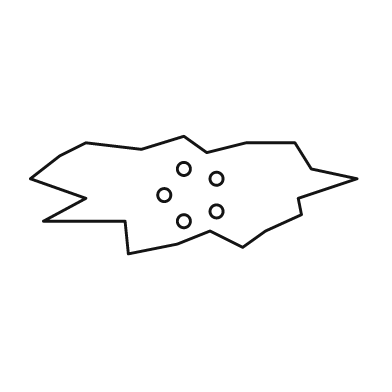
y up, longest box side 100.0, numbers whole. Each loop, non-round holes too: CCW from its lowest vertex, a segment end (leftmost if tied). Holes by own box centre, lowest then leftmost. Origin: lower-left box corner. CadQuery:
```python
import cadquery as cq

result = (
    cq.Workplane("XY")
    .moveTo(30.0, 0.0)
    .lineTo(45.0, 3.0)
    .lineTo(55.0, 7.0)
    .lineTo(65.0, 2.0)
    .lineTo(72.0, 7.0)
    .lineTo(83.0, 12.0)
    .lineTo(82.0, 17.0)
    .lineTo(100.0, 23.0)
    .lineTo(86.0, 26.0)
    .lineTo(81.0, 34.0)
    .lineTo(66.0, 34.0)
    .lineTo(54.0, 31.0)
    .lineTo(47.0, 36.0)
    .lineTo(34.0, 32.0)
    .lineTo(17.0, 34.0)
    .lineTo(9.0, 30.0)
    .lineTo(0.0, 23.0)
    .lineTo(17.0, 17.0)
    .lineTo(4.0, 10.0)
    .lineTo(29.0, 10.0)
    .close()
    .moveTo(47.0, 10.0)
    .circle(2.0)
    .moveTo(57.0, 13.0)
    .circle(2.0)
    .moveTo(41.0, 18.0)
    .circle(2.0)
    .moveTo(57.0, 23.0)
    .circle(2.0)
    .moveTo(47.0, 26.0)
    .circle(2.0)
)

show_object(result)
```